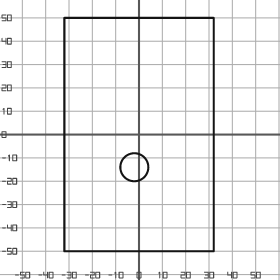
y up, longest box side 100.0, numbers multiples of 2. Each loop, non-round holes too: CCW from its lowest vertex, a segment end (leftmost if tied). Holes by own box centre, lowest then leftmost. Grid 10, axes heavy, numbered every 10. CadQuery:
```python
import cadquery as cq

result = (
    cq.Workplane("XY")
    .moveTo(-32.0, -50.0)
    .lineTo(32.0, -50.0)
    .lineTo(32.0, 50.0)
    .lineTo(-32.0, 50.0)
    .close()
    .moveTo(-2.0, -14.0)
    .circle(6.0)
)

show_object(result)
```